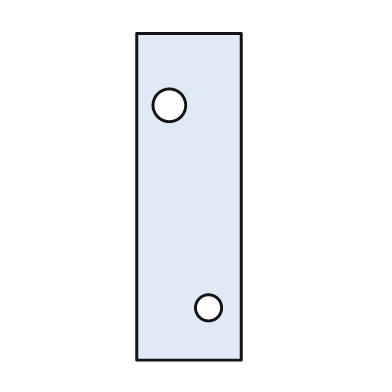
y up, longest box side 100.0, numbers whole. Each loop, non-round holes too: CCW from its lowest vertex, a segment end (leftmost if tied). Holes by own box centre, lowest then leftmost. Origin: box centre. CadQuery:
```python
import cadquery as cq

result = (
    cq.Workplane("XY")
    .moveTo(-16.0, -50.0)
    .lineTo(16.0, -50.0)
    .lineTo(16.0, 50.0)
    .lineTo(-16.0, 50.0)
    .close()
    .moveTo(6.0, -34.0)
    .circle(4.0)
    .moveTo(-6.0, 28.0)
    .circle(5.0)
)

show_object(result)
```